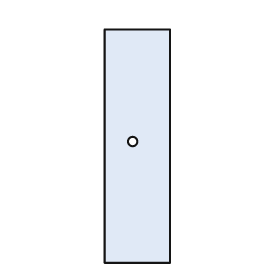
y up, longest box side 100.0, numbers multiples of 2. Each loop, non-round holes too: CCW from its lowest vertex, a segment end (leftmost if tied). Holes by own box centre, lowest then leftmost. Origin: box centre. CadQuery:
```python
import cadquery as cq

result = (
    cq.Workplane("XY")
    .moveTo(-14.0, -50.0)
    .lineTo(14.0, -50.0)
    .lineTo(14.0, 50.0)
    .lineTo(-14.0, 50.0)
    .close()
    .moveTo(-2.0, 2.0)
    .circle(2.0)
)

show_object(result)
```